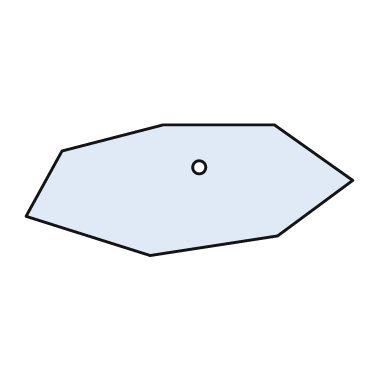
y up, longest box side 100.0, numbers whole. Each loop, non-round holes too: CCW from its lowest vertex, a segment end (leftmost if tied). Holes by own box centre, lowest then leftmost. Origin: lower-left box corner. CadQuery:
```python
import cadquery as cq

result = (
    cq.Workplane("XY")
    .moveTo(38.0, 0.0)
    .lineTo(77.0, 6.0)
    .lineTo(100.0, 23.0)
    .lineTo(76.0, 40.0)
    .lineTo(42.0, 40.0)
    .lineTo(11.0, 32.0)
    .lineTo(0.0, 12.0)
    .close()
    .moveTo(53.0, 27.0)
    .circle(2.0)
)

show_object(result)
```